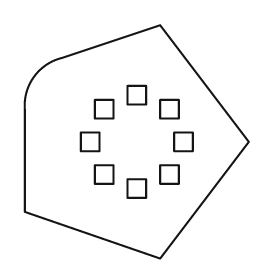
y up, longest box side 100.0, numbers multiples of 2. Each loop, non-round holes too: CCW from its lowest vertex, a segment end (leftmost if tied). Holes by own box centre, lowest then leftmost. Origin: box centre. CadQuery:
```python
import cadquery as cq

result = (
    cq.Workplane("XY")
    .moveTo(10.0, -50.0)
    .lineTo(48.0, 0.0)
    .lineTo(10.0, 50.0)
    .lineTo(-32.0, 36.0)
    .threePointArc((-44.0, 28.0), (-48.0, 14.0))
    .lineTo(-48.0, -30.0)
    .close()
    .moveTo(-4.0, -24.0)
    .lineTo(4.0, -24.0)
    .lineTo(4.0, -16.0)
    .lineTo(-4.0, -16.0)
    .close()
    .moveTo(-18.0, -18.0)
    .lineTo(-10.0, -18.0)
    .lineTo(-10.0, -10.0)
    .lineTo(-18.0, -10.0)
    .close()
    .moveTo(10.0, -18.0)
    .lineTo(18.0, -18.0)
    .lineTo(18.0, -10.0)
    .lineTo(10.0, -10.0)
    .close()
    .moveTo(-24.0, -4.0)
    .lineTo(-16.0, -4.0)
    .lineTo(-16.0, 4.0)
    .lineTo(-24.0, 4.0)
    .close()
    .moveTo(16.0, -4.0)
    .lineTo(24.0, -4.0)
    .lineTo(24.0, 4.0)
    .lineTo(16.0, 4.0)
    .close()
    .moveTo(-18.0, 10.0)
    .lineTo(-10.0, 10.0)
    .lineTo(-10.0, 18.0)
    .lineTo(-18.0, 18.0)
    .close()
    .moveTo(10.0, 10.0)
    .lineTo(18.0, 10.0)
    .lineTo(18.0, 18.0)
    .lineTo(10.0, 18.0)
    .close()
    .moveTo(-4.0, 16.0)
    .lineTo(4.0, 16.0)
    .lineTo(4.0, 24.0)
    .lineTo(-4.0, 24.0)
    .close()
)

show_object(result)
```